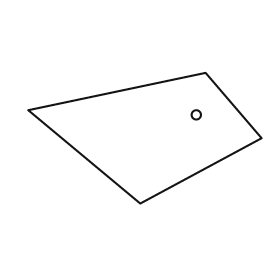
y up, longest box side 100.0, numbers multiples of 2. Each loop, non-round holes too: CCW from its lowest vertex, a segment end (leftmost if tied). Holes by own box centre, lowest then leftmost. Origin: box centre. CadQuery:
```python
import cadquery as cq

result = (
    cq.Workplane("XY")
    .moveTo(-2.0, -28.0)
    .lineTo(50.0, 0.0)
    .lineTo(26.0, 28.0)
    .lineTo(-50.0, 12.0)
    .close()
    .moveTo(22.0, 10.0)
    .circle(2.0)
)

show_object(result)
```